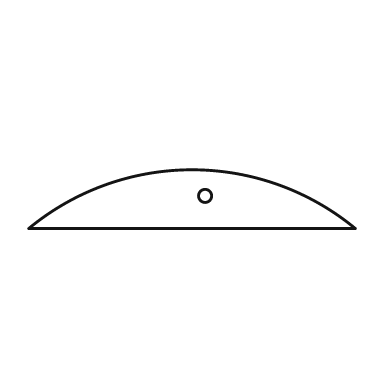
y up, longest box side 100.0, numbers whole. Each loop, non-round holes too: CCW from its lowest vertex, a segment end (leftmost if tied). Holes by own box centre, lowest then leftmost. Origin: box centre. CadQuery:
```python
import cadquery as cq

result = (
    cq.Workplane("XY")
    .moveTo(-50.0, -9.0)
    .lineTo(50.0, -9.0)
    .threePointArc((0.0, 9.0), (-50.0, -9.0))
    .close()
    .moveTo(4.0, 1.0)
    .circle(2.0)
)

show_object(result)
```